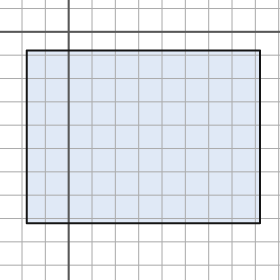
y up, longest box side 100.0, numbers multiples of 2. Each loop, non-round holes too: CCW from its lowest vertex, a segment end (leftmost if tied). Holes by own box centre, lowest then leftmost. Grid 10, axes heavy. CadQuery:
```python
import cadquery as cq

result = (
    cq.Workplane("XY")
    .moveTo(-18.0, -82.0)
    .lineTo(82.0, -82.0)
    .lineTo(82.0, -8.0)
    .lineTo(-18.0, -8.0)
    .close()
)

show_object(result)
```